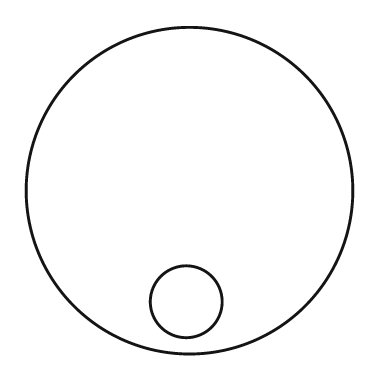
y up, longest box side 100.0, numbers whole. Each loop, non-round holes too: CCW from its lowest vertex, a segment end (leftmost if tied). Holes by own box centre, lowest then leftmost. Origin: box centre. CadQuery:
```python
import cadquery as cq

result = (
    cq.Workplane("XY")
    .moveTo(0.0, 0.0)
    .circle(50.0)
    .moveTo(-1.0, -34.0)
    .circle(11.0)
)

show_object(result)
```